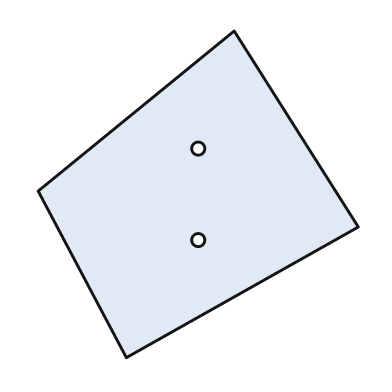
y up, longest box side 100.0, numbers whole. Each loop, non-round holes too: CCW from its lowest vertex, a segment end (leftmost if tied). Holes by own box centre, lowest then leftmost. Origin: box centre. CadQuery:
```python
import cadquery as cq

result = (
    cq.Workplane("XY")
    .moveTo(-22.0, -50.0)
    .lineTo(49.0, -10.0)
    .lineTo(11.0, 50.0)
    .lineTo(-49.0, 1.0)
    .close()
    .moveTo(0.0, -14.0)
    .circle(2.0)
    .moveTo(0.0, 14.0)
    .circle(2.0)
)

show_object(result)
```